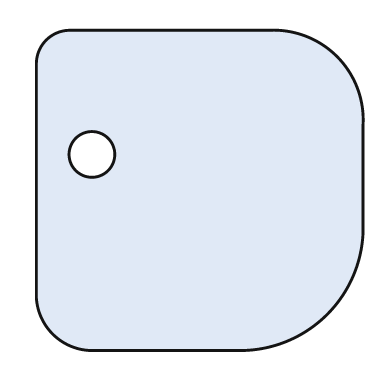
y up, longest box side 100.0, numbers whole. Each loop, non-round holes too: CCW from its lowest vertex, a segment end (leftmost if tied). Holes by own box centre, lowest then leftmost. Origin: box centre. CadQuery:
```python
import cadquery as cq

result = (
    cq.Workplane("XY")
    .moveTo(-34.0, -49.0)
    .lineTo(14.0, -49.0)
    .threePointArc((39.0, -38.0), (50.0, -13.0))
    .lineTo(50.0, 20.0)
    .threePointArc((42.0, 41.0), (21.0, 49.0))
    .lineTo(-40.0, 49.0)
    .threePointArc((-47.0, 46.0), (-50.0, 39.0))
    .lineTo(-50.0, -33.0)
    .threePointArc((-45.0, -44.0), (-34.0, -49.0))
    .close()
    .moveTo(-33.0, 11.0)
    .circle(7.0)
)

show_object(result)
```